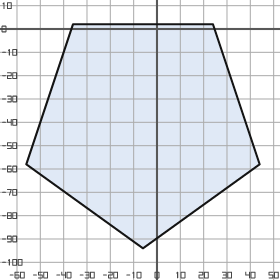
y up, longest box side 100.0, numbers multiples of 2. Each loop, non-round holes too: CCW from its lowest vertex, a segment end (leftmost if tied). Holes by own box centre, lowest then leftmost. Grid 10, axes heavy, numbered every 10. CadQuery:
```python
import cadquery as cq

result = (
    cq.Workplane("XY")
    .moveTo(-6.0, -94.0)
    .lineTo(44.0, -58.0)
    .lineTo(24.0, 2.0)
    .lineTo(-36.0, 2.0)
    .lineTo(-56.0, -58.0)
    .close()
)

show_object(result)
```